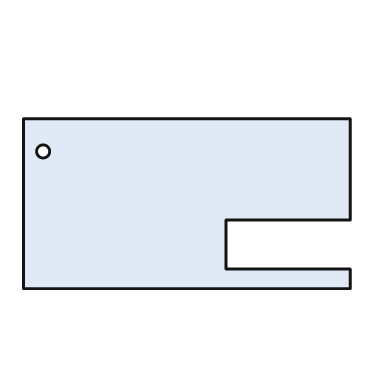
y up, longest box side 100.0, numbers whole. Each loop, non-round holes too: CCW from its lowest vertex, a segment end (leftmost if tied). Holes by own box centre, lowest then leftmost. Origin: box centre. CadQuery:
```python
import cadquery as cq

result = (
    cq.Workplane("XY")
    .moveTo(-50.0, -26.0)
    .lineTo(50.0, -26.0)
    .lineTo(50.0, -20.0)
    .lineTo(12.0, -20.0)
    .lineTo(12.0, -5.0)
    .lineTo(50.0, -5.0)
    .lineTo(50.0, 26.0)
    .lineTo(-50.0, 26.0)
    .close()
    .moveTo(-44.0, 16.0)
    .circle(2.0)
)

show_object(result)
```